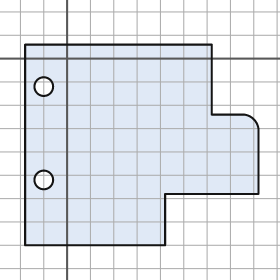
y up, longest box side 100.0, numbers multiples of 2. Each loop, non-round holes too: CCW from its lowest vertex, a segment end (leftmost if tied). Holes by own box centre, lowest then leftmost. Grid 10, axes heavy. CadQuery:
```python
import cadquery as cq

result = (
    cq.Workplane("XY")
    .moveTo(-18.0, -80.0)
    .lineTo(42.0, -80.0)
    .lineTo(42.0, -58.0)
    .lineTo(82.0, -58.0)
    .lineTo(82.0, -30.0)
    .threePointArc((80.0, -26.0), (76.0, -24.0))
    .lineTo(62.0, -24.0)
    .lineTo(62.0, 6.0)
    .lineTo(-18.0, 6.0)
    .close()
    .moveTo(-10.0, -52.0)
    .circle(4.0)
    .moveTo(-10.0, -12.0)
    .circle(4.0)
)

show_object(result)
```